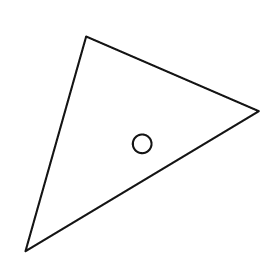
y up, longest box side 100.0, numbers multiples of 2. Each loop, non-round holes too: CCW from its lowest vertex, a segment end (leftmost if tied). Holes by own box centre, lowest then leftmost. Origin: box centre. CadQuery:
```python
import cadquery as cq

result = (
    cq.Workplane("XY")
    .moveTo(-50.0, -46.0)
    .lineTo(50.0, 14.0)
    .lineTo(-24.0, 46.0)
    .close()
    .moveTo(0.0, 0.0)
    .circle(4.0)
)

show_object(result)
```